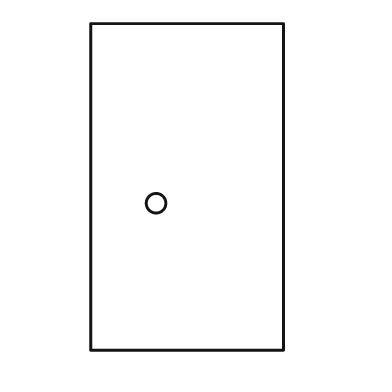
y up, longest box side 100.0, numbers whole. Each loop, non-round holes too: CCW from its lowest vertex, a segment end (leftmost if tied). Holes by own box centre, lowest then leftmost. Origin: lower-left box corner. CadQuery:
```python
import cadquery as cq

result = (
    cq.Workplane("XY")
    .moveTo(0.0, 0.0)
    .lineTo(59.0, 0.0)
    .lineTo(59.0, 100.0)
    .lineTo(0.0, 100.0)
    .close()
    .moveTo(20.0, 45.0)
    .circle(3.0)
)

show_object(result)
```